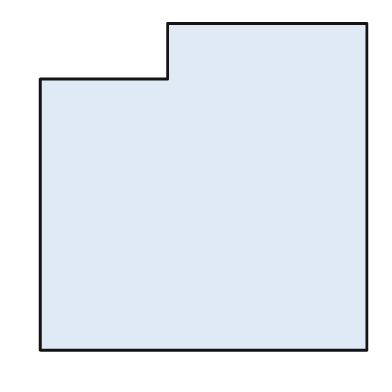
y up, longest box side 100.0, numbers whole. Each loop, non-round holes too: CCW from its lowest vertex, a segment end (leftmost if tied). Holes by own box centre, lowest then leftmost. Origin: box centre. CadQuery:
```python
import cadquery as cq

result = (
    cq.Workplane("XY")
    .moveTo(-50.0, -50.0)
    .lineTo(50.0, -50.0)
    .lineTo(50.0, 50.0)
    .lineTo(-11.0, 50.0)
    .lineTo(-11.0, 33.0)
    .lineTo(-50.0, 33.0)
    .close()
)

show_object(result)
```